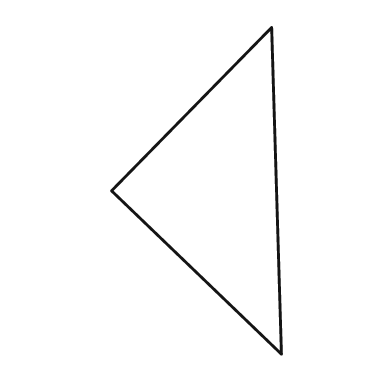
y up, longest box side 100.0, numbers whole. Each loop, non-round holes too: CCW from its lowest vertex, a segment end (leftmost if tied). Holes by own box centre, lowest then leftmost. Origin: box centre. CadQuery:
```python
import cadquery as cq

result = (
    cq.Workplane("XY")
    .moveTo(26.0, -50.0)
    .lineTo(23.0, 50.0)
    .lineTo(-26.0, 0.0)
    .close()
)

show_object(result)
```